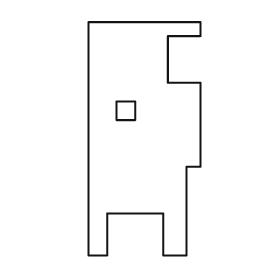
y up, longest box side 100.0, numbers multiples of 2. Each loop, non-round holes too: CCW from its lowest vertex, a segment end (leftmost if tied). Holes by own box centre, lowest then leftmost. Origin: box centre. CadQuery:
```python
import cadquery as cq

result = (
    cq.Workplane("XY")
    .moveTo(-24.0, -50.0)
    .lineTo(-16.0, -50.0)
    .lineTo(-16.0, -32.0)
    .lineTo(8.0, -32.0)
    .lineTo(8.0, -50.0)
    .lineTo(18.0, -50.0)
    .lineTo(18.0, -12.0)
    .lineTo(24.0, -12.0)
    .lineTo(24.0, 24.0)
    .lineTo(10.0, 24.0)
    .lineTo(10.0, 44.0)
    .lineTo(24.0, 44.0)
    .lineTo(24.0, 50.0)
    .lineTo(-24.0, 50.0)
    .close()
    .moveTo(-12.0, 8.0)
    .lineTo(-4.0, 8.0)
    .lineTo(-4.0, 16.0)
    .lineTo(-12.0, 16.0)
    .close()
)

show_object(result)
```